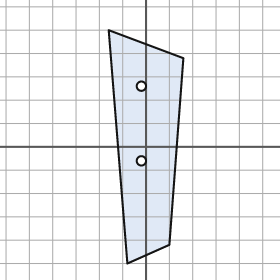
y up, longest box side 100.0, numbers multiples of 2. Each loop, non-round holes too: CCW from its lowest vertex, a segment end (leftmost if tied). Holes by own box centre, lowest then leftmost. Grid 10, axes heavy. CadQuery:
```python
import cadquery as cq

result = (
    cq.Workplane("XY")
    .moveTo(-8.0, -50.0)
    .lineTo(10.0, -42.0)
    .lineTo(16.0, 38.0)
    .lineTo(-16.0, 50.0)
    .close()
    .moveTo(-2.0, -6.0)
    .circle(2.0)
    .moveTo(-2.0, 26.0)
    .circle(2.0)
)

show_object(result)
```